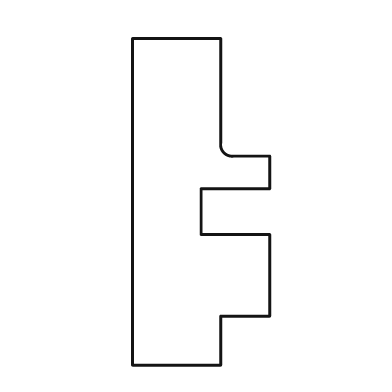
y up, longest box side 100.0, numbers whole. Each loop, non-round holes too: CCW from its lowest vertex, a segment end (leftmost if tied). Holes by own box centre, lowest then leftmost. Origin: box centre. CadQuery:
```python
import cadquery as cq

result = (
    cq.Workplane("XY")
    .moveTo(-21.0, -50.0)
    .lineTo(6.0, -50.0)
    .lineTo(6.0, -35.0)
    .lineTo(21.0, -35.0)
    .lineTo(21.0, -10.0)
    .lineTo(0.0, -10.0)
    .lineTo(0.0, 4.0)
    .lineTo(21.0, 4.0)
    .lineTo(21.0, 14.0)
    .lineTo(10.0, 14.0)
    .threePointArc((7.0, 15.0), (6.0, 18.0))
    .lineTo(6.0, 50.0)
    .lineTo(-21.0, 50.0)
    .close()
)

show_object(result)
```